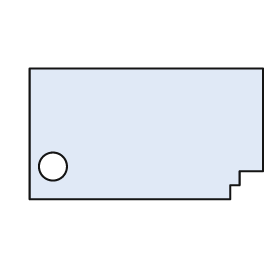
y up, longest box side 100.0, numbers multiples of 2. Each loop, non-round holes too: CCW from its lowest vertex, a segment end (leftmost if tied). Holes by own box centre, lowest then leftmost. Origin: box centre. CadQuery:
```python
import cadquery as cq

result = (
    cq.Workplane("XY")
    .moveTo(-50.0, -28.0)
    .lineTo(36.0, -28.0)
    .lineTo(36.0, -22.0)
    .lineTo(40.0, -22.0)
    .lineTo(40.0, -16.0)
    .lineTo(50.0, -16.0)
    .lineTo(50.0, 28.0)
    .lineTo(-50.0, 28.0)
    .close()
    .moveTo(-40.0, -14.0)
    .circle(6.0)
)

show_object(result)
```